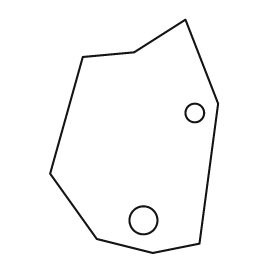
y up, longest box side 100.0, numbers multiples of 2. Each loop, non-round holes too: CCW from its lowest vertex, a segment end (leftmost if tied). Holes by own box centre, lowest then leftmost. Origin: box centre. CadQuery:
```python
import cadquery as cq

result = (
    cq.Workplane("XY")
    .moveTo(8.0, -50.0)
    .lineTo(28.0, -46.0)
    .lineTo(36.0, 14.0)
    .lineTo(22.0, 50.0)
    .lineTo(0.0, 36.0)
    .lineTo(-22.0, 34.0)
    .lineTo(-36.0, -16.0)
    .lineTo(-16.0, -44.0)
    .close()
    .moveTo(4.0, -36.0)
    .circle(6.0)
    .moveTo(26.0, 10.0)
    .circle(4.0)
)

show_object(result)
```